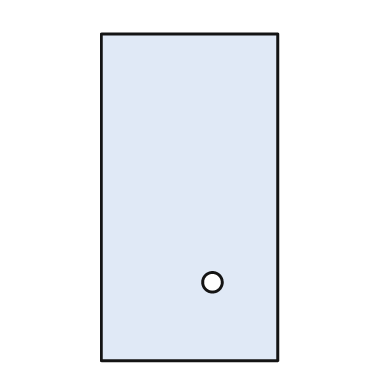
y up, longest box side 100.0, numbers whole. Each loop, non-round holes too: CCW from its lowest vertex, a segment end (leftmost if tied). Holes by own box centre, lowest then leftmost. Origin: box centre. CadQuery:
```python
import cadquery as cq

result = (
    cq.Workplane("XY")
    .moveTo(-27.0, -50.0)
    .lineTo(27.0, -50.0)
    .lineTo(27.0, 50.0)
    .lineTo(-27.0, 50.0)
    .close()
    .moveTo(7.0, -26.0)
    .circle(3.0)
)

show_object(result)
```